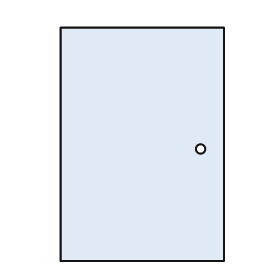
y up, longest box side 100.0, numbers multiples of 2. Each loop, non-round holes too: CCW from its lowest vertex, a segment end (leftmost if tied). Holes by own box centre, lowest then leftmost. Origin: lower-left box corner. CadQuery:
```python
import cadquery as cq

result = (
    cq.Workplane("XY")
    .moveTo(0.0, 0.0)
    .lineTo(70.0, 0.0)
    .lineTo(70.0, 100.0)
    .lineTo(0.0, 100.0)
    .close()
    .moveTo(60.0, 48.0)
    .circle(2.0)
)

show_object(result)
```